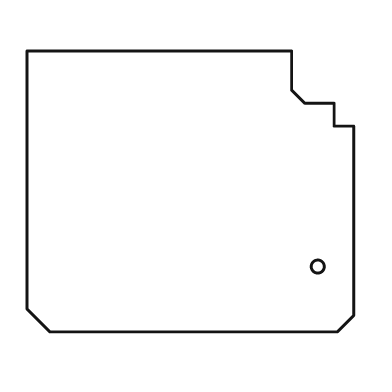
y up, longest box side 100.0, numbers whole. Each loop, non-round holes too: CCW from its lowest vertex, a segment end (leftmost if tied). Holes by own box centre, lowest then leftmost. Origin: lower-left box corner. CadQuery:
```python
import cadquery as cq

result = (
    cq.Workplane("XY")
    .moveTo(7.0, 0.0)
    .lineTo(95.0, 0.0)
    .lineTo(100.0, 5.0)
    .lineTo(100.0, 63.0)
    .lineTo(94.0, 63.0)
    .lineTo(94.0, 70.0)
    .lineTo(85.0, 70.0)
    .lineTo(81.0, 74.0)
    .lineTo(81.0, 86.0)
    .lineTo(0.0, 86.0)
    .lineTo(0.0, 7.0)
    .close()
    .moveTo(89.0, 20.0)
    .circle(2.0)
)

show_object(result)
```